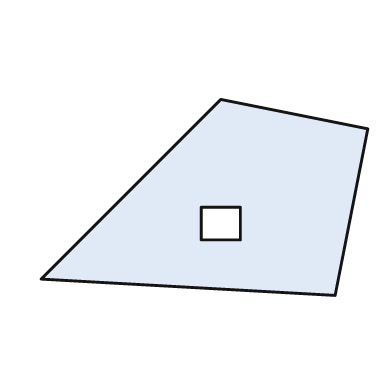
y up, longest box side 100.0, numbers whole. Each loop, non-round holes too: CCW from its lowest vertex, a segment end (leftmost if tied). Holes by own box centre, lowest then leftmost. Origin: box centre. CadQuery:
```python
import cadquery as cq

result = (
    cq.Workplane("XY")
    .moveTo(40.0, -30.0)
    .lineTo(50.0, 21.0)
    .lineTo(5.0, 30.0)
    .lineTo(-50.0, -25.0)
    .close()
    .moveTo(-1.0, -13.0)
    .lineTo(11.0, -13.0)
    .lineTo(11.0, -3.0)
    .lineTo(-1.0, -3.0)
    .close()
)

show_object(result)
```